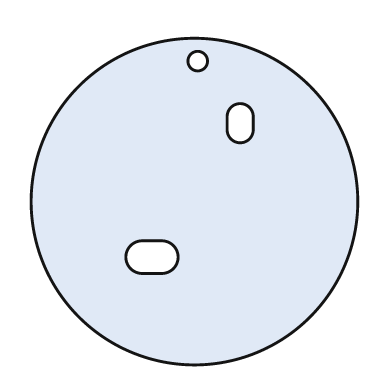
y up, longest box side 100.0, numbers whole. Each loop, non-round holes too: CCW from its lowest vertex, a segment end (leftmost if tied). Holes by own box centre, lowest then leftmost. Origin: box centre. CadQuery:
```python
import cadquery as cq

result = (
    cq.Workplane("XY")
    .moveTo(0.0, 0.0)
    .circle(50.0)
    .moveTo(-16.0, -22.0)
    .lineTo(-10.0, -22.0)
    .threePointArc((-5.0, -17.0), (-10.0, -12.0))
    .lineTo(-16.0, -12.0)
    .threePointArc((-21.0, -17.0), (-16.0, -22.0))
    .close()
    .moveTo(10.0, 22.0)
    .threePointArc((14.0, 18.0), (18.0, 22.0))
    .lineTo(18.0, 26.0)
    .threePointArc((14.0, 30.0), (10.0, 26.0))
    .close()
    .moveTo(1.0, 43.0)
    .circle(3.0)
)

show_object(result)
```